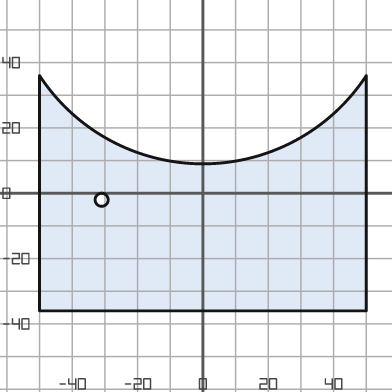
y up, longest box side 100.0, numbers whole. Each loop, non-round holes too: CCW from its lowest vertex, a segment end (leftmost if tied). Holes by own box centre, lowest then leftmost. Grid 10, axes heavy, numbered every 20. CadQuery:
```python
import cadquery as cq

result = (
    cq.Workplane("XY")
    .moveTo(-50.0, -36.0)
    .lineTo(50.0, -36.0)
    .lineTo(50.0, 36.0)
    .threePointArc((0.0, 9.0), (-50.0, 36.0))
    .close()
    .moveTo(-31.0, -2.0)
    .circle(2.0)
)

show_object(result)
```